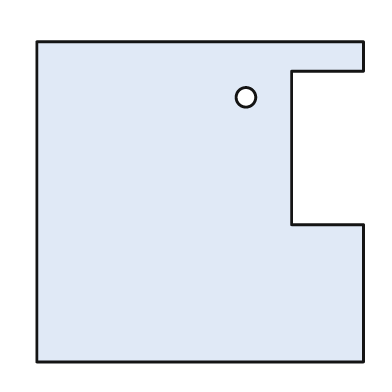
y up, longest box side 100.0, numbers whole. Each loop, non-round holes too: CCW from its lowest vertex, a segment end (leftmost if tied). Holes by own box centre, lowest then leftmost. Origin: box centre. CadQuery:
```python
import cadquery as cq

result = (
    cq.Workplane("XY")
    .moveTo(-50.0, -49.0)
    .lineTo(50.0, -49.0)
    .lineTo(50.0, -7.0)
    .lineTo(28.0, -7.0)
    .lineTo(28.0, 40.0)
    .lineTo(50.0, 40.0)
    .lineTo(50.0, 49.0)
    .lineTo(-50.0, 49.0)
    .close()
    .moveTo(14.0, 32.0)
    .circle(3.0)
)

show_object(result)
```